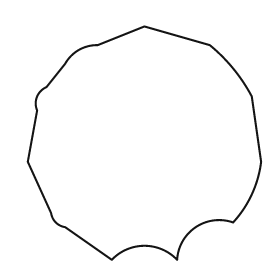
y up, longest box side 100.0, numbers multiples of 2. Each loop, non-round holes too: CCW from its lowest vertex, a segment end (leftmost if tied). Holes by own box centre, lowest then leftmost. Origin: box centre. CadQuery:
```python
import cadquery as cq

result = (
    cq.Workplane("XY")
    .moveTo(-14.0, -50.0)
    .threePointArc((0.0, -44.0), (14.0, -50.0))
    .threePointArc((22.0, -36.0), (38.0, -34.0))
    .threePointArc((46.0, -22.0), (50.0, -8.0))
    .lineTo(46.0, 20.0)
    .threePointArc((38.0, 32.0), (28.0, 42.0))
    .lineTo(0.0, 50.0)
    .lineTo(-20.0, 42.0)
    .threePointArc((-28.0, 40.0), (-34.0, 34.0))
    .lineTo(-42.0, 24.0)
    .threePointArc((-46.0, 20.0), (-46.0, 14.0))
    .lineTo(-50.0, -8.0)
    .lineTo(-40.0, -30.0)
    .threePointArc((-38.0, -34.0), (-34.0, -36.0))
    .close()
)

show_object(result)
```